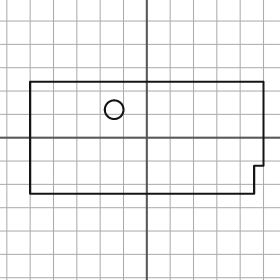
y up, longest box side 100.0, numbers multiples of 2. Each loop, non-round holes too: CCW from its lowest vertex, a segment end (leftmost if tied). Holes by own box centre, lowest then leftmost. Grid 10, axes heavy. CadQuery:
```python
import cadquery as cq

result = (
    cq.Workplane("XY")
    .moveTo(-50.0, -24.0)
    .lineTo(46.0, -24.0)
    .lineTo(46.0, -12.0)
    .lineTo(50.0, -12.0)
    .lineTo(50.0, 24.0)
    .lineTo(-50.0, 24.0)
    .close()
    .moveTo(-14.0, 12.0)
    .circle(4.0)
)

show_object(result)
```